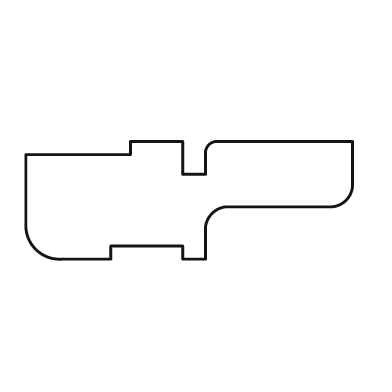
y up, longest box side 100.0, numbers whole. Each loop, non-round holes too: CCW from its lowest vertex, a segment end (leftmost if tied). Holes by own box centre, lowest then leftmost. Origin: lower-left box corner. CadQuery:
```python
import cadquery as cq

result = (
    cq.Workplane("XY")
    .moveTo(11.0, 0.0)
    .lineTo(26.0, 0.0)
    .lineTo(26.0, 4.0)
    .lineTo(48.0, 4.0)
    .lineTo(48.0, 0.0)
    .lineTo(55.0, 0.0)
    .lineTo(55.0, 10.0)
    .threePointArc((57.0, 14.0), (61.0, 16.0))
    .lineTo(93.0, 16.0)
    .threePointArc((98.0, 18.0), (100.0, 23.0))
    .lineTo(100.0, 36.0)
    .lineTo(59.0, 36.0)
    .threePointArc((56.0, 35.0), (55.0, 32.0))
    .lineTo(55.0, 26.0)
    .lineTo(48.0, 26.0)
    .lineTo(48.0, 36.0)
    .lineTo(32.0, 36.0)
    .lineTo(32.0, 32.0)
    .lineTo(0.0, 32.0)
    .lineTo(0.0, 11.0)
    .threePointArc((3.0, 3.0), (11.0, 0.0))
    .close()
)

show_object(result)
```